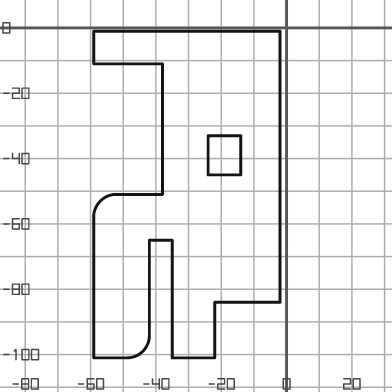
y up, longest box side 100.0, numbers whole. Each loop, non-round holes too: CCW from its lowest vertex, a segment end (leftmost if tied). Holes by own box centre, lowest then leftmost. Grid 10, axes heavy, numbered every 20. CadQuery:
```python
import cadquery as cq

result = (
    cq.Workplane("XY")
    .moveTo(-59.0, -101.0)
    .lineTo(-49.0, -101.0)
    .threePointArc((-44.0, -99.0), (-42.0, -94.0))
    .lineTo(-42.0, -65.0)
    .lineTo(-35.0, -65.0)
    .lineTo(-35.0, -101.0)
    .lineTo(-22.0, -101.0)
    .lineTo(-22.0, -84.0)
    .lineTo(-2.0, -84.0)
    .lineTo(-2.0, -1.0)
    .lineTo(-59.0, -1.0)
    .lineTo(-59.0, -11.0)
    .lineTo(-38.0, -11.0)
    .lineTo(-38.0, -51.0)
    .lineTo(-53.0, -51.0)
    .threePointArc((-57.0, -53.0), (-59.0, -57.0))
    .close()
    .moveTo(-24.0, -45.0)
    .lineTo(-14.0, -45.0)
    .lineTo(-14.0, -33.0)
    .lineTo(-24.0, -33.0)
    .close()
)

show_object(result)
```